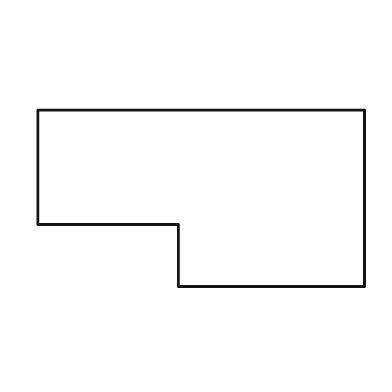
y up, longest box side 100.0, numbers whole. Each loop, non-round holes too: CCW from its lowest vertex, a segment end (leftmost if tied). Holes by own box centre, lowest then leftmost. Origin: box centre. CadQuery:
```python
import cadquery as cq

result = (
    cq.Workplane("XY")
    .moveTo(-7.0, -27.0)
    .lineTo(50.0, -27.0)
    .lineTo(50.0, 27.0)
    .lineTo(-50.0, 27.0)
    .lineTo(-50.0, -8.0)
    .lineTo(-7.0, -8.0)
    .close()
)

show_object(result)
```